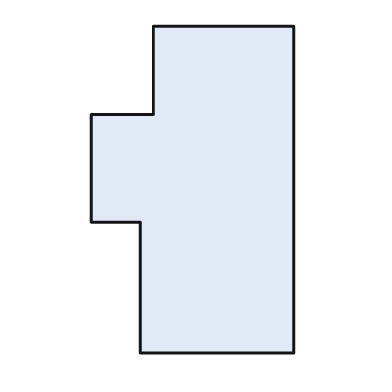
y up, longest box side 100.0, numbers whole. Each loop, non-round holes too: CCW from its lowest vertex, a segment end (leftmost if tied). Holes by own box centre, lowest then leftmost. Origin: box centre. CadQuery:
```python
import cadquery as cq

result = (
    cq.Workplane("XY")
    .moveTo(-16.0, -50.0)
    .lineTo(31.0, -50.0)
    .lineTo(31.0, 50.0)
    .lineTo(-12.0, 50.0)
    .lineTo(-12.0, 23.0)
    .lineTo(-31.0, 23.0)
    .lineTo(-31.0, -10.0)
    .lineTo(-16.0, -10.0)
    .close()
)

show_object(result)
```